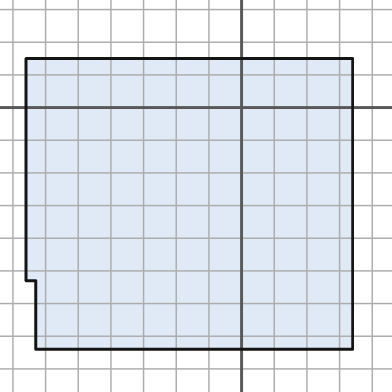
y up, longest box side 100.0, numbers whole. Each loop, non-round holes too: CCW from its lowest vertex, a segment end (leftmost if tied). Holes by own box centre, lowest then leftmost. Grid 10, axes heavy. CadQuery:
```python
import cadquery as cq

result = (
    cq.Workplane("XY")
    .moveTo(-63.0, -74.0)
    .lineTo(34.0, -74.0)
    .lineTo(34.0, 15.0)
    .lineTo(-66.0, 15.0)
    .lineTo(-66.0, -53.0)
    .lineTo(-63.0, -53.0)
    .close()
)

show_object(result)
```